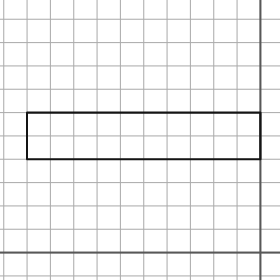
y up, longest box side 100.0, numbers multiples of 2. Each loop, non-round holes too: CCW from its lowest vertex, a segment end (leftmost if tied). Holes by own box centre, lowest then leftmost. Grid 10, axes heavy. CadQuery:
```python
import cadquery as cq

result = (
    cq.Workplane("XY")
    .moveTo(-100.0, 40.0)
    .lineTo(0.0, 40.0)
    .lineTo(0.0, 60.0)
    .lineTo(-100.0, 60.0)
    .close()
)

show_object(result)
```